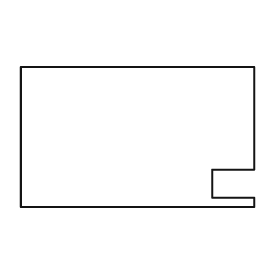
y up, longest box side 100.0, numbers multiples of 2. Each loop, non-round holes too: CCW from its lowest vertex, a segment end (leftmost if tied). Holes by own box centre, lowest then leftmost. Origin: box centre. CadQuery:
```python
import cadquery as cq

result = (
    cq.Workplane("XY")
    .moveTo(-50.0, -30.0)
    .lineTo(50.0, -30.0)
    .lineTo(50.0, -26.0)
    .lineTo(32.0, -26.0)
    .lineTo(32.0, -14.0)
    .lineTo(50.0, -14.0)
    .lineTo(50.0, 30.0)
    .lineTo(-50.0, 30.0)
    .close()
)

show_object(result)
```